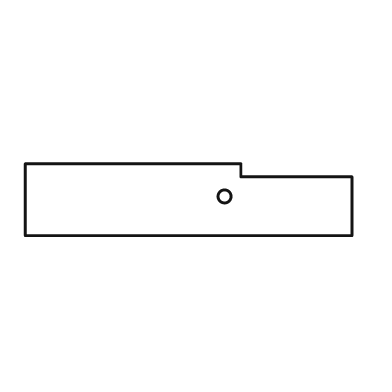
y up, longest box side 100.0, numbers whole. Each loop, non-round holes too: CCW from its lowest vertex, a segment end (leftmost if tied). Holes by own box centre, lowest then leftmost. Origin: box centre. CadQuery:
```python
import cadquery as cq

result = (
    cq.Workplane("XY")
    .moveTo(-50.0, -11.0)
    .lineTo(50.0, -11.0)
    .lineTo(50.0, 7.0)
    .lineTo(16.0, 7.0)
    .lineTo(16.0, 11.0)
    .lineTo(-50.0, 11.0)
    .close()
    .moveTo(11.0, 1.0)
    .circle(2.0)
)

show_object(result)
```